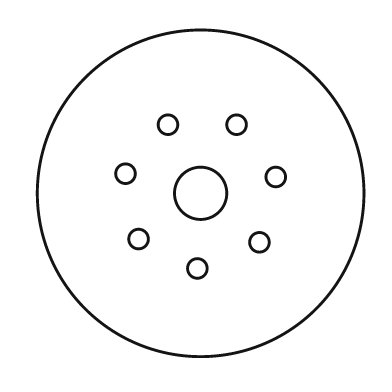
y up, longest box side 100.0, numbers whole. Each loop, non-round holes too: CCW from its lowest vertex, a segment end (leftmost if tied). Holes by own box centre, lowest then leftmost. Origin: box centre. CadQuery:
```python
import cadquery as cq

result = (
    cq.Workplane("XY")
    .moveTo(0.0, 0.0)
    .circle(50.0)
    .moveTo(-1.0, -23.0)
    .circle(3.0)
    .moveTo(18.0, -15.0)
    .circle(3.0)
    .moveTo(-19.0, -14.0)
    .circle(3.0)
    .moveTo(0.0, 0.0)
    .circle(8.0)
    .moveTo(23.0, 5.0)
    .circle(3.0)
    .moveTo(-23.0, 6.0)
    .circle(3.0)
    .moveTo(-10.0, 21.0)
    .circle(3.0)
    .moveTo(11.0, 21.0)
    .circle(3.0)
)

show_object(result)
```